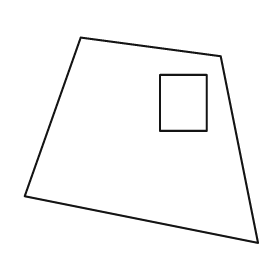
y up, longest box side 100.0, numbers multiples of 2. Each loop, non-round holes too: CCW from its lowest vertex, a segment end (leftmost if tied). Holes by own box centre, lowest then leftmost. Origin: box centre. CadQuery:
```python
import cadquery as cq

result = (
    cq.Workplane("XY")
    .moveTo(50.0, -44.0)
    .lineTo(34.0, 36.0)
    .lineTo(-26.0, 44.0)
    .lineTo(-50.0, -24.0)
    .close()
    .moveTo(8.0, 4.0)
    .lineTo(28.0, 4.0)
    .lineTo(28.0, 28.0)
    .lineTo(8.0, 28.0)
    .close()
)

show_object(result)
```